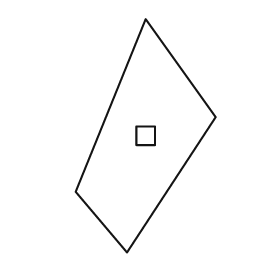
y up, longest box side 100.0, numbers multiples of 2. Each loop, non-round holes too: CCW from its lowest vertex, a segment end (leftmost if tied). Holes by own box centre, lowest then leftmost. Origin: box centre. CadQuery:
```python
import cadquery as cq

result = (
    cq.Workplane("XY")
    .moveTo(-8.0, -50.0)
    .lineTo(30.0, 8.0)
    .lineTo(0.0, 50.0)
    .lineTo(-30.0, -24.0)
    .close()
    .moveTo(-4.0, -4.0)
    .lineTo(4.0, -4.0)
    .lineTo(4.0, 4.0)
    .lineTo(-4.0, 4.0)
    .close()
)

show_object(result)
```